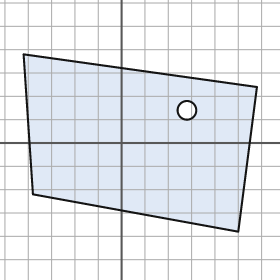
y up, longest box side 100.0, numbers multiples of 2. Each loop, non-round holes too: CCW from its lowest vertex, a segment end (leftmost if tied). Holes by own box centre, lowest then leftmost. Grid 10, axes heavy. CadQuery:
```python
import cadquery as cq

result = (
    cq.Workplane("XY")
    .moveTo(50.0, -38.0)
    .lineTo(58.0, 24.0)
    .lineTo(-42.0, 38.0)
    .lineTo(-38.0, -22.0)
    .close()
    .moveTo(28.0, 14.0)
    .circle(4.0)
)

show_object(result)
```